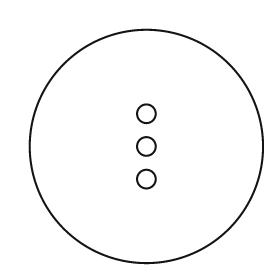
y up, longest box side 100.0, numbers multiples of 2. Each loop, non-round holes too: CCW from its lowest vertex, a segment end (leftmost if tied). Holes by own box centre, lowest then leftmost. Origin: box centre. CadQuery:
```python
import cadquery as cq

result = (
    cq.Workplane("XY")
    .moveTo(0.0, 0.0)
    .circle(50.0)
    .moveTo(0.0, -14.0)
    .circle(4.0)
    .moveTo(0.0, 0.0)
    .circle(4.0)
    .moveTo(0.0, 14.0)
    .circle(4.0)
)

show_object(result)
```